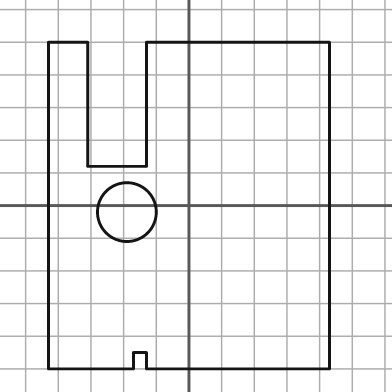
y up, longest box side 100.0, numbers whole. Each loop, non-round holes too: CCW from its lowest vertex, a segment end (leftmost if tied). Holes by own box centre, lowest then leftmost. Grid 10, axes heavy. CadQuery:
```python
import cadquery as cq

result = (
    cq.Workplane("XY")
    .moveTo(-43.0, -50.0)
    .lineTo(-17.0, -50.0)
    .lineTo(-17.0, -45.0)
    .lineTo(-13.0, -45.0)
    .lineTo(-13.0, -50.0)
    .lineTo(43.0, -50.0)
    .lineTo(43.0, 50.0)
    .lineTo(-13.0, 50.0)
    .lineTo(-13.0, 12.0)
    .lineTo(-31.0, 12.0)
    .lineTo(-31.0, 50.0)
    .lineTo(-43.0, 50.0)
    .close()
    .moveTo(-19.0, -2.0)
    .circle(9.0)
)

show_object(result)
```